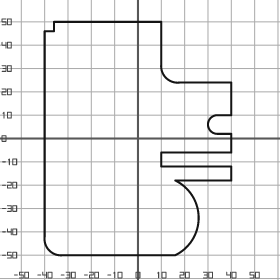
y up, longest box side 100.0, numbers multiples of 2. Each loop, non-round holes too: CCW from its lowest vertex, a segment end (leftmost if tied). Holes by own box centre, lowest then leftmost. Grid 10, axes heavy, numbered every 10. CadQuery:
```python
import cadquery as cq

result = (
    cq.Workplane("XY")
    .moveTo(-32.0, -50.0)
    .lineTo(16.0, -50.0)
    .threePointArc((26.0, -34.0), (16.0, -18.0))
    .lineTo(40.0, -18.0)
    .lineTo(40.0, -12.0)
    .lineTo(10.0, -12.0)
    .lineTo(10.0, -6.0)
    .lineTo(40.0, -6.0)
    .lineTo(40.0, 2.0)
    .lineTo(34.0, 2.0)
    .threePointArc((30.0, 6.0), (34.0, 10.0))
    .lineTo(40.0, 10.0)
    .lineTo(40.0, 24.0)
    .lineTo(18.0, 24.0)
    .threePointArc((12.0, 26.0), (10.0, 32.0))
    .lineTo(10.0, 50.0)
    .lineTo(-36.0, 50.0)
    .lineTo(-36.0, 46.0)
    .lineTo(-40.0, 46.0)
    .lineTo(-40.0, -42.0)
    .threePointArc((-38.0, -48.0), (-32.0, -50.0))
    .close()
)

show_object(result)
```